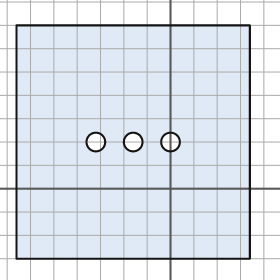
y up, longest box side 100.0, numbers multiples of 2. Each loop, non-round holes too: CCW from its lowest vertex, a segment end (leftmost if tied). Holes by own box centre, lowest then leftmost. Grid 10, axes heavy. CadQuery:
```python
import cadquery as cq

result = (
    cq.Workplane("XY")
    .moveTo(-66.0, -30.0)
    .lineTo(34.0, -30.0)
    .lineTo(34.0, 70.0)
    .lineTo(-66.0, 70.0)
    .close()
    .moveTo(-32.0, 20.0)
    .circle(4.0)
    .moveTo(-16.0, 20.0)
    .circle(4.0)
    .moveTo(0.0, 20.0)
    .circle(4.0)
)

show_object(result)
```